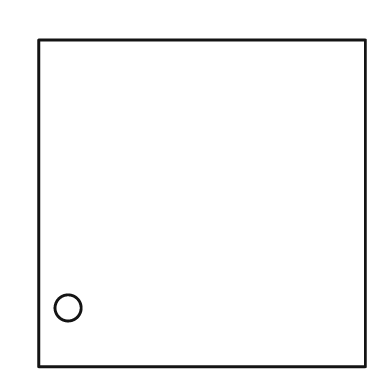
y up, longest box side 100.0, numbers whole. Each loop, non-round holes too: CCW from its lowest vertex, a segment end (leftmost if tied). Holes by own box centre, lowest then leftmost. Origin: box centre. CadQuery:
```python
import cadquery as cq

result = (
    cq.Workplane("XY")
    .moveTo(-50.0, -50.0)
    .lineTo(50.0, -50.0)
    .lineTo(50.0, 50.0)
    .lineTo(-50.0, 50.0)
    .close()
    .moveTo(-41.0, -32.0)
    .circle(4.0)
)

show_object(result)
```